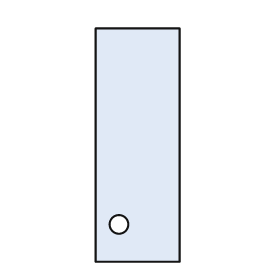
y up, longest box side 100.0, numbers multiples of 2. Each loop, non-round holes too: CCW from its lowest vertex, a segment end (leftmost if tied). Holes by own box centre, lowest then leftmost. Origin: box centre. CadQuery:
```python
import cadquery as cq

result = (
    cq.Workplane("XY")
    .moveTo(-18.0, -50.0)
    .lineTo(18.0, -50.0)
    .lineTo(18.0, 50.0)
    .lineTo(-18.0, 50.0)
    .close()
    .moveTo(-8.0, -34.0)
    .circle(4.0)
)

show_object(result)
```